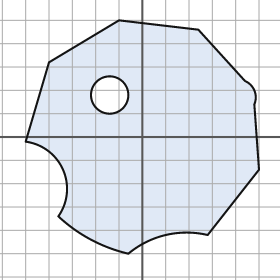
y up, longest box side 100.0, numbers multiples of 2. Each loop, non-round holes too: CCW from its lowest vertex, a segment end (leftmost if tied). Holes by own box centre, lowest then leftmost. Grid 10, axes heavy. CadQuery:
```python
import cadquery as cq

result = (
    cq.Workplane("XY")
    .moveTo(-6.0, -50.0)
    .threePointArc((10.0, -42.0), (28.0, -42.0))
    .lineTo(50.0, -14.0)
    .lineTo(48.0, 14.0)
    .threePointArc((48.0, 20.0), (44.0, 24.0))
    .lineTo(24.0, 46.0)
    .lineTo(-10.0, 50.0)
    .lineTo(-40.0, 32.0)
    .lineTo(-50.0, -2.0)
    .threePointArc((-34.0, -14.0), (-36.0, -34.0))
    .threePointArc((-22.0, -44.0), (-6.0, -50.0))
    .close()
    .moveTo(-14.0, 18.0)
    .circle(8.0)
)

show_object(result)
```